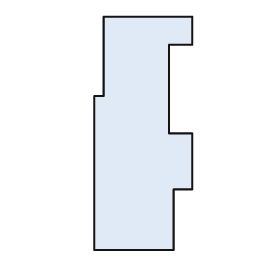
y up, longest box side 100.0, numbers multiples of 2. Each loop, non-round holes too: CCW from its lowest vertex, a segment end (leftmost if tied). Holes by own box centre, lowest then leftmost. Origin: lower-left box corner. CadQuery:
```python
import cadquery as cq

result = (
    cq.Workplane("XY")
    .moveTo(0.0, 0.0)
    .lineTo(34.0, 0.0)
    .lineTo(34.0, 26.0)
    .lineTo(42.0, 26.0)
    .lineTo(42.0, 50.0)
    .lineTo(32.0, 50.0)
    .lineTo(32.0, 88.0)
    .lineTo(42.0, 88.0)
    .lineTo(42.0, 100.0)
    .lineTo(4.0, 100.0)
    .lineTo(4.0, 66.0)
    .lineTo(0.0, 66.0)
    .close()
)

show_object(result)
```